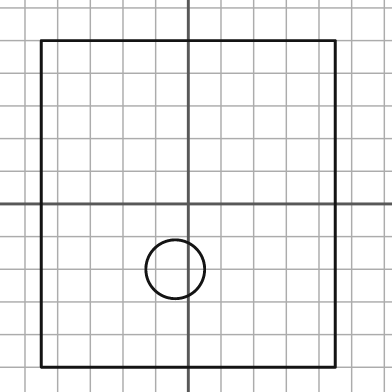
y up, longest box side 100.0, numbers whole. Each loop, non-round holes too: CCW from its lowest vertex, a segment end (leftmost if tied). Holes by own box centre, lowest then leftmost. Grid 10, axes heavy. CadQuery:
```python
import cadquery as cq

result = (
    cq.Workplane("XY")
    .moveTo(-45.0, -50.0)
    .lineTo(45.0, -50.0)
    .lineTo(45.0, 50.0)
    .lineTo(-45.0, 50.0)
    .close()
    .moveTo(-4.0, -20.0)
    .circle(9.0)
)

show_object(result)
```